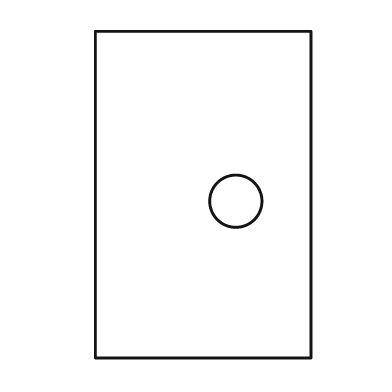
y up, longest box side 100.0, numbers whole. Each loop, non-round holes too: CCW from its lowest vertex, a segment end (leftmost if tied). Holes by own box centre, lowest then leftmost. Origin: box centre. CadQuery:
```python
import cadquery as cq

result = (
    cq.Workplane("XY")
    .moveTo(-33.0, -50.0)
    .lineTo(33.0, -50.0)
    .lineTo(33.0, 50.0)
    .lineTo(-33.0, 50.0)
    .close()
    .moveTo(10.0, -2.0)
    .circle(8.0)
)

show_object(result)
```